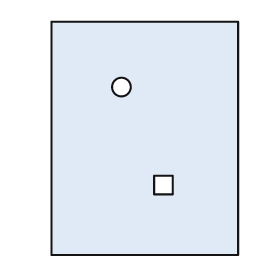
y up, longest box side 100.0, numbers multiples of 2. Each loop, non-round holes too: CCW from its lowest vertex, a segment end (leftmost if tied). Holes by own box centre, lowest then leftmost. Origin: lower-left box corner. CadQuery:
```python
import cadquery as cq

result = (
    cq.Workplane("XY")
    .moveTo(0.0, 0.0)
    .lineTo(80.0, 0.0)
    .lineTo(80.0, 100.0)
    .lineTo(0.0, 100.0)
    .close()
    .moveTo(44.0, 26.0)
    .lineTo(52.0, 26.0)
    .lineTo(52.0, 34.0)
    .lineTo(44.0, 34.0)
    .close()
    .moveTo(30.0, 72.0)
    .circle(4.0)
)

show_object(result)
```